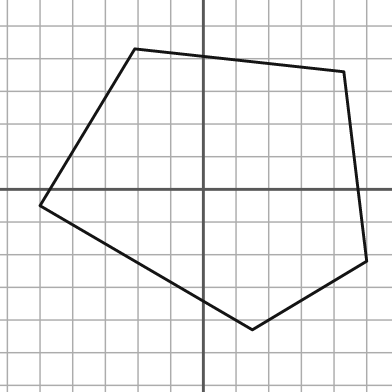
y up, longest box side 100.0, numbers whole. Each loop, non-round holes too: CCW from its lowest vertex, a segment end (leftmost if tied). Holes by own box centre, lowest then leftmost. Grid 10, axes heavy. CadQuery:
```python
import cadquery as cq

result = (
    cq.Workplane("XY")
    .moveTo(15.0, -43.0)
    .lineTo(50.0, -22.0)
    .lineTo(43.0, 36.0)
    .lineTo(-21.0, 43.0)
    .lineTo(-50.0, -5.0)
    .close()
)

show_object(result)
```